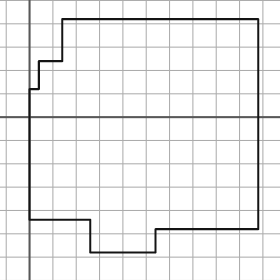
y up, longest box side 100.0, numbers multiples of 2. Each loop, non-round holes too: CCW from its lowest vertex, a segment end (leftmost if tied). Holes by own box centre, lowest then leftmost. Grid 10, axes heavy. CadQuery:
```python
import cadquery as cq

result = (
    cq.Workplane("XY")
    .moveTo(26.0, -58.0)
    .lineTo(54.0, -58.0)
    .lineTo(54.0, -48.0)
    .lineTo(98.0, -48.0)
    .lineTo(98.0, 42.0)
    .lineTo(14.0, 42.0)
    .lineTo(14.0, 24.0)
    .lineTo(4.0, 24.0)
    .lineTo(4.0, 12.0)
    .lineTo(0.0, 12.0)
    .lineTo(0.0, -44.0)
    .lineTo(26.0, -44.0)
    .close()
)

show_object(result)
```